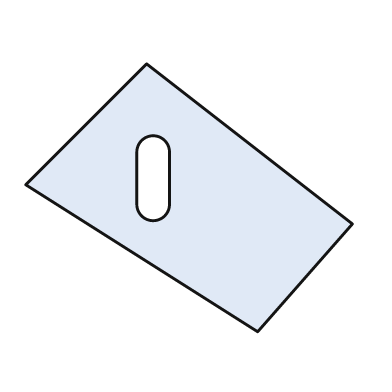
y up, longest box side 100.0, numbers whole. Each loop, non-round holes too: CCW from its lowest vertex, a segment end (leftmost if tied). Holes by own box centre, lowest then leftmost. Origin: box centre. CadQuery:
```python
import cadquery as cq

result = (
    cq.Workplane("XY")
    .moveTo(21.0, -41.0)
    .lineTo(50.0, -8.0)
    .lineTo(-13.0, 41.0)
    .lineTo(-50.0, 4.0)
    .close()
    .moveTo(-16.0, -2.0)
    .threePointArc((-11.0, -7.0), (-6.0, -2.0))
    .lineTo(-6.0, 14.0)
    .threePointArc((-11.0, 19.0), (-16.0, 14.0))
    .close()
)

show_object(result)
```